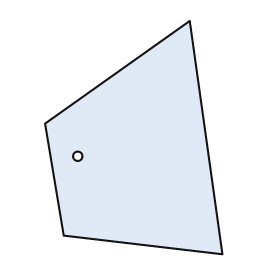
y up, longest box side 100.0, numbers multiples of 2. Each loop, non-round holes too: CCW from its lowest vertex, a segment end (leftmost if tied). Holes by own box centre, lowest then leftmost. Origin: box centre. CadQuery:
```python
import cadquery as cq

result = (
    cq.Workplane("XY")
    .moveTo(38.0, -50.0)
    .lineTo(24.0, 50.0)
    .lineTo(-38.0, 6.0)
    .lineTo(-30.0, -42.0)
    .close()
    .moveTo(-24.0, -8.0)
    .circle(2.0)
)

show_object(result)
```